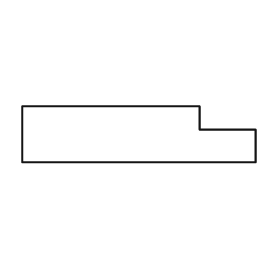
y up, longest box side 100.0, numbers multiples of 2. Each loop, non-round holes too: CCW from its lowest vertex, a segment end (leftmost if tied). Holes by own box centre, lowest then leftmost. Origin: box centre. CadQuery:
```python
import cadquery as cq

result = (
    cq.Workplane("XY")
    .moveTo(-50.0, -12.0)
    .lineTo(50.0, -12.0)
    .lineTo(50.0, 2.0)
    .lineTo(26.0, 2.0)
    .lineTo(26.0, 12.0)
    .lineTo(-50.0, 12.0)
    .close()
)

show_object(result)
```